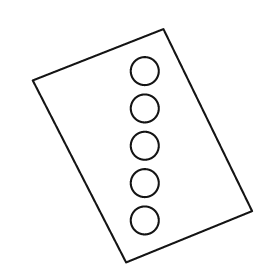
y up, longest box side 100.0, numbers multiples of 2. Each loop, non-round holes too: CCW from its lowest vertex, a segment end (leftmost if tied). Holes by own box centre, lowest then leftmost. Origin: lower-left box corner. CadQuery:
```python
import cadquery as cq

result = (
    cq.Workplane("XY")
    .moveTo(40.0, 0.0)
    .lineTo(94.0, 22.0)
    .lineTo(56.0, 100.0)
    .lineTo(0.0, 78.0)
    .close()
    .moveTo(48.0, 18.0)
    .circle(6.0)
    .moveTo(48.0, 34.0)
    .circle(6.0)
    .moveTo(48.0, 50.0)
    .circle(6.0)
    .moveTo(48.0, 66.0)
    .circle(6.0)
    .moveTo(48.0, 82.0)
    .circle(6.0)
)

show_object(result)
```